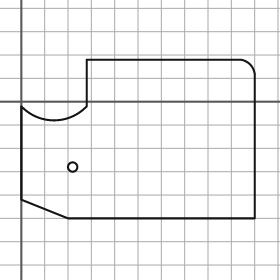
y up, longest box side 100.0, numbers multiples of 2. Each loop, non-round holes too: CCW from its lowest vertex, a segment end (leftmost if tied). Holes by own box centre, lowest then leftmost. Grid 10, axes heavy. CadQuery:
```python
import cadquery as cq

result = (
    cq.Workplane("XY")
    .moveTo(20.0, -50.0)
    .lineTo(100.0, -50.0)
    .lineTo(100.0, 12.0)
    .threePointArc((98.0, 16.0), (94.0, 18.0))
    .lineTo(28.0, 18.0)
    .lineTo(28.0, -2.0)
    .threePointArc((14.0, -8.0), (0.0, -2.0))
    .lineTo(0.0, -42.0)
    .close()
    .moveTo(22.0, -28.0)
    .circle(2.0)
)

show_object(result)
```